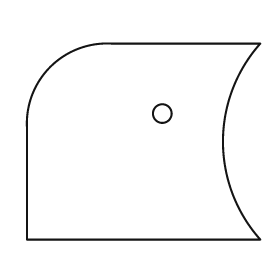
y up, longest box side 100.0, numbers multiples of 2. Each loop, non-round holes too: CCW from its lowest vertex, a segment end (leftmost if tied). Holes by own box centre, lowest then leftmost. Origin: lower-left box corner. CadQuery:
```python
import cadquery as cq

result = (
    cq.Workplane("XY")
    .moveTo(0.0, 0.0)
    .lineTo(100.0, 0.0)
    .threePointArc((84.0, 42.0), (100.0, 84.0))
    .lineTo(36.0, 84.0)
    .threePointArc((10.0, 74.0), (0.0, 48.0))
    .close()
    .moveTo(58.0, 54.0)
    .circle(4.0)
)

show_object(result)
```